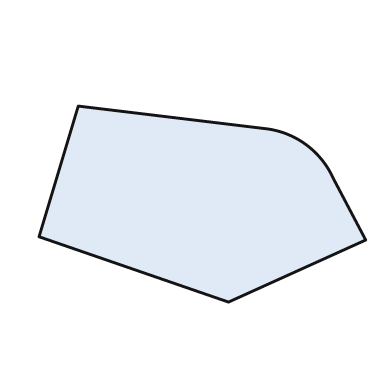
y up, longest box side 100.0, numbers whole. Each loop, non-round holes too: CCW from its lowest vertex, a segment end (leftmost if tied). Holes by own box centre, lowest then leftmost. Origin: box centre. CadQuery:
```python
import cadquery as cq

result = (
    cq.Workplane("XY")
    .moveTo(8.0, -30.0)
    .lineTo(50.0, -11.0)
    .lineTo(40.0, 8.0)
    .threePointArc((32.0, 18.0), (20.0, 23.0))
    .lineTo(-38.0, 30.0)
    .lineTo(-50.0, -10.0)
    .close()
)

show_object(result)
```